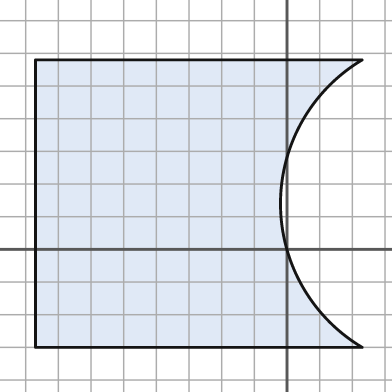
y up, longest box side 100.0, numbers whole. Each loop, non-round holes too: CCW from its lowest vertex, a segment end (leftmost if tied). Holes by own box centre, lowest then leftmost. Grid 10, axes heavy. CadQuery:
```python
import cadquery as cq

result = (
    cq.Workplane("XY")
    .moveTo(-77.0, -30.0)
    .lineTo(23.0, -30.0)
    .threePointArc((-2.0, 14.0), (23.0, 58.0))
    .lineTo(-77.0, 58.0)
    .close()
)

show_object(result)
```